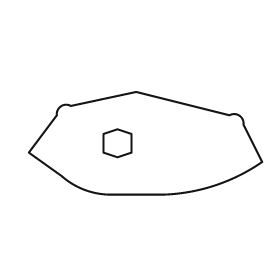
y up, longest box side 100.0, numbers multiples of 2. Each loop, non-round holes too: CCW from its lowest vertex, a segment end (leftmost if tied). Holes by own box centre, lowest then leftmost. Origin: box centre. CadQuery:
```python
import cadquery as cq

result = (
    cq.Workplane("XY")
    .moveTo(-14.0, -22.0)
    .lineTo(8.0, -22.0)
    .threePointArc((30.0, -18.0), (50.0, -8.0))
    .lineTo(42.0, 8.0)
    .threePointArc((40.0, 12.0), (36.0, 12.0))
    .lineTo(-4.0, 22.0)
    .lineTo(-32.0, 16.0)
    .threePointArc((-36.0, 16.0), (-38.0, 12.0))
    .lineTo(-50.0, -4.0)
    .lineTo(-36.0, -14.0)
    .threePointArc((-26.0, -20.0), (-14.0, -22.0))
    .close()
    .moveTo(-12.0, -6.0)
    .lineTo(-6.0, -4.0)
    .lineTo(-6.0, 4.0)
    .lineTo(-12.0, 6.0)
    .lineTo(-18.0, 4.0)
    .lineTo(-18.0, -4.0)
    .close()
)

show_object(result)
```